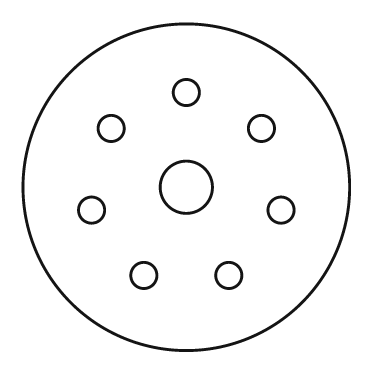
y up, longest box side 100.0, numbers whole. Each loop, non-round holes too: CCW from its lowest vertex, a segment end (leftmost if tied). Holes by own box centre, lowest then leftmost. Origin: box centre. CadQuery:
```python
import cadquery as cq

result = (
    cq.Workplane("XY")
    .moveTo(0.0, 0.0)
    .circle(50.0)
    .moveTo(-13.0, -27.0)
    .circle(4.0)
    .moveTo(13.0, -27.0)
    .circle(4.0)
    .moveTo(-29.0, -7.0)
    .circle(4.0)
    .moveTo(29.0, -7.0)
    .circle(4.0)
    .moveTo(0.0, 0.0)
    .circle(8.0)
    .moveTo(-23.0, 18.0)
    .circle(4.0)
    .moveTo(23.0, 18.0)
    .circle(4.0)
    .moveTo(0.0, 29.0)
    .circle(4.0)
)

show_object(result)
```